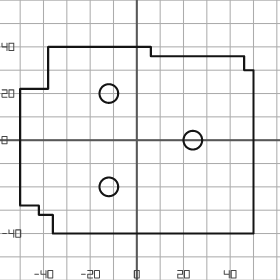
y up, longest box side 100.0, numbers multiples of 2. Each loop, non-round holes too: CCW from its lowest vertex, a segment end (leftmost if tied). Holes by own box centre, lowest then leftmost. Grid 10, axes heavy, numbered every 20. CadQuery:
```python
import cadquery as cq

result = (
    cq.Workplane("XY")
    .moveTo(-36.0, -40.0)
    .lineTo(50.0, -40.0)
    .lineTo(50.0, 30.0)
    .lineTo(46.0, 30.0)
    .lineTo(46.0, 36.0)
    .lineTo(6.0, 36.0)
    .lineTo(6.0, 40.0)
    .lineTo(-38.0, 40.0)
    .lineTo(-38.0, 22.0)
    .lineTo(-50.0, 22.0)
    .lineTo(-50.0, -28.0)
    .lineTo(-42.0, -28.0)
    .lineTo(-42.0, -32.0)
    .lineTo(-36.0, -32.0)
    .close()
    .moveTo(-12.0, -20.0)
    .circle(4.0)
    .moveTo(24.0, 0.0)
    .circle(4.0)
    .moveTo(-12.0, 20.0)
    .circle(4.0)
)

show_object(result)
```